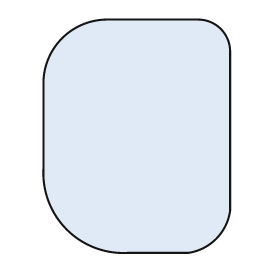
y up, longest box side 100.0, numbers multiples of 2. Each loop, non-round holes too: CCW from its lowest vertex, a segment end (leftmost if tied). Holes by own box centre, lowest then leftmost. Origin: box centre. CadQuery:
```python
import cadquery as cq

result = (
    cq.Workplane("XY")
    .moveTo(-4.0, -50.0)
    .lineTo(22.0, -50.0)
    .threePointArc((34.0, -44.0), (40.0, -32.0))
    .lineTo(40.0, 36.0)
    .threePointArc((36.0, 46.0), (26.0, 50.0))
    .lineTo(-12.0, 50.0)
    .threePointArc((-32.0, 42.0), (-40.0, 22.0))
    .lineTo(-40.0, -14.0)
    .threePointArc((-30.0, -40.0), (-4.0, -50.0))
    .close()
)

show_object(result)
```